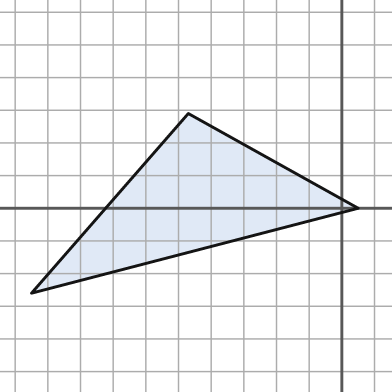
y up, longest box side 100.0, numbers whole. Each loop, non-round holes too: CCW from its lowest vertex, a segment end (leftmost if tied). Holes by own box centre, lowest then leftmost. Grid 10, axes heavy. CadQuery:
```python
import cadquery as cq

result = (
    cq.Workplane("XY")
    .moveTo(-95.0, -26.0)
    .lineTo(5.0, 0.0)
    .lineTo(-47.0, 29.0)
    .close()
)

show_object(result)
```